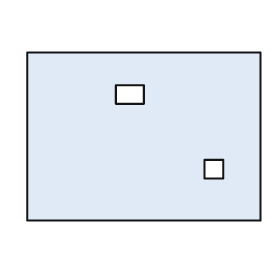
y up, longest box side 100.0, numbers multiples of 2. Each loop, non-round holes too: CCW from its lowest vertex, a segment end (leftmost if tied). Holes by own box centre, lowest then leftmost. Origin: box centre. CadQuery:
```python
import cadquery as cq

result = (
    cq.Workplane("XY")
    .moveTo(-50.0, -36.0)
    .lineTo(50.0, -36.0)
    .lineTo(50.0, 36.0)
    .lineTo(-50.0, 36.0)
    .close()
    .moveTo(26.0, -18.0)
    .lineTo(34.0, -18.0)
    .lineTo(34.0, -10.0)
    .lineTo(26.0, -10.0)
    .close()
    .moveTo(-12.0, 14.0)
    .lineTo(0.0, 14.0)
    .lineTo(0.0, 22.0)
    .lineTo(-12.0, 22.0)
    .close()
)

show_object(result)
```